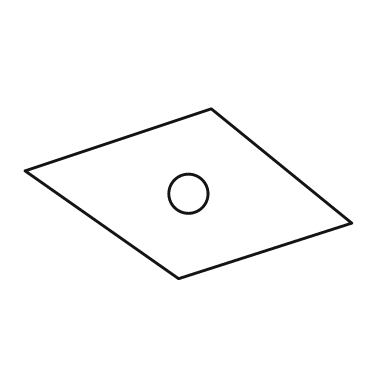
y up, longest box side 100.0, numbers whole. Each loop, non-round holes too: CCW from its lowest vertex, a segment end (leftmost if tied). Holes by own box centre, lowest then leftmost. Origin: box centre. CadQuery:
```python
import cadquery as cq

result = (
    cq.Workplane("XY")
    .moveTo(-3.0, -26.0)
    .lineTo(50.0, -9.0)
    .lineTo(7.0, 26.0)
    .lineTo(-50.0, 7.0)
    .close()
    .moveTo(0.0, 0.0)
    .circle(6.0)
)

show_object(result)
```